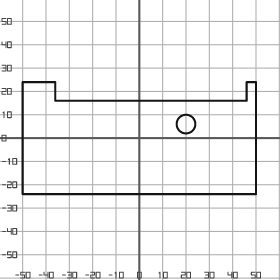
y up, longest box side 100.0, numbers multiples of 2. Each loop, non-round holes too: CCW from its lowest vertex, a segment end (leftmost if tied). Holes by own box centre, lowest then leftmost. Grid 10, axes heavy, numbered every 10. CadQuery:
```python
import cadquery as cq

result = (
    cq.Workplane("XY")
    .moveTo(-50.0, -24.0)
    .lineTo(50.0, -24.0)
    .lineTo(50.0, 24.0)
    .lineTo(46.0, 24.0)
    .lineTo(46.0, 16.0)
    .lineTo(-36.0, 16.0)
    .lineTo(-36.0, 24.0)
    .lineTo(-50.0, 24.0)
    .close()
    .moveTo(20.0, 6.0)
    .circle(4.0)
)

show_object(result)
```